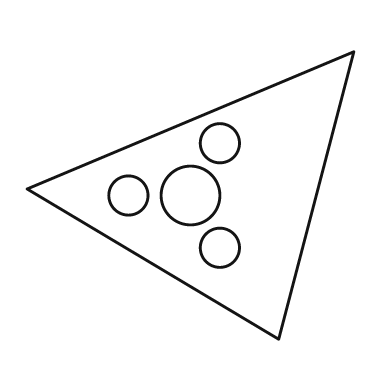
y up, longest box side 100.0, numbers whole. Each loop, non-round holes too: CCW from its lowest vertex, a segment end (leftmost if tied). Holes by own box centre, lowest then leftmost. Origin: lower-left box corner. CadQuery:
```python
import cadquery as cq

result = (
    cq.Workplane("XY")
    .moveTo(77.0, 0.0)
    .lineTo(100.0, 88.0)
    .lineTo(0.0, 46.0)
    .close()
    .moveTo(59.0, 28.0)
    .circle(6.0)
    .moveTo(31.0, 44.0)
    .circle(6.0)
    .moveTo(50.0, 44.0)
    .circle(9.0)
    .moveTo(59.0, 60.0)
    .circle(6.0)
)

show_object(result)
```